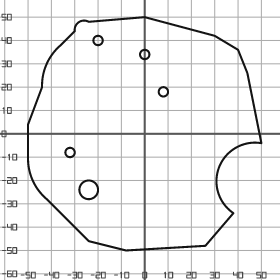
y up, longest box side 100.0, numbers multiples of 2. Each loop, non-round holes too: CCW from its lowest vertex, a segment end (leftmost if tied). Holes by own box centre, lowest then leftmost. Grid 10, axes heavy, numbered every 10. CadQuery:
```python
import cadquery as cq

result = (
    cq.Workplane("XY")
    .moveTo(-8.0, -50.0)
    .lineTo(26.0, -48.0)
    .lineTo(38.0, -34.0)
    .threePointArc((32.0, -14.0), (50.0, -4.0))
    .lineTo(44.0, 26.0)
    .lineTo(40.0, 36.0)
    .lineTo(30.0, 42.0)
    .lineTo(0.0, 50.0)
    .lineTo(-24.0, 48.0)
    .threePointArc((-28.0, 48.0), (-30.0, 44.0))
    .lineTo(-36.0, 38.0)
    .threePointArc((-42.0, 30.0), (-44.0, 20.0))
    .lineTo(-50.0, 4.0)
    .lineTo(-50.0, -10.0)
    .threePointArc((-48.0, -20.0), (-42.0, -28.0))
    .lineTo(-24.0, -46.0)
    .close()
    .moveTo(-24.0, -24.0)
    .circle(4.0)
    .moveTo(-32.0, -8.0)
    .circle(2.0)
    .moveTo(8.0, 18.0)
    .circle(2.0)
    .moveTo(0.0, 34.0)
    .circle(2.0)
    .moveTo(-20.0, 40.0)
    .circle(2.0)
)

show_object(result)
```